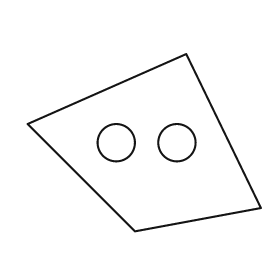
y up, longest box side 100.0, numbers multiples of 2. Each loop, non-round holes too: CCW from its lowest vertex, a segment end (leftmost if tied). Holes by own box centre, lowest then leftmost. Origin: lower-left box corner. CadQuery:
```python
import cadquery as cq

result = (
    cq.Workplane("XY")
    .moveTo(46.0, 0.0)
    .lineTo(100.0, 10.0)
    .lineTo(68.0, 76.0)
    .lineTo(0.0, 46.0)
    .close()
    .moveTo(38.0, 38.0)
    .circle(8.0)
    .moveTo(64.0, 38.0)
    .circle(8.0)
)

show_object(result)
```